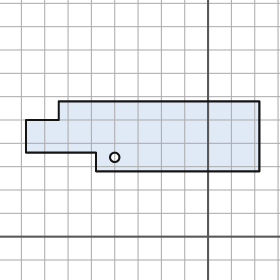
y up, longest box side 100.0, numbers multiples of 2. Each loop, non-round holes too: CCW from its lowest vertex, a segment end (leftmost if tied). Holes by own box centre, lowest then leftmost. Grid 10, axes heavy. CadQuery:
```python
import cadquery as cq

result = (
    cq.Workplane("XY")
    .moveTo(-48.0, 28.0)
    .lineTo(22.0, 28.0)
    .lineTo(22.0, 58.0)
    .lineTo(-64.0, 58.0)
    .lineTo(-64.0, 50.0)
    .lineTo(-78.0, 50.0)
    .lineTo(-78.0, 36.0)
    .lineTo(-48.0, 36.0)
    .close()
    .moveTo(-40.0, 34.0)
    .circle(2.0)
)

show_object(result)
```